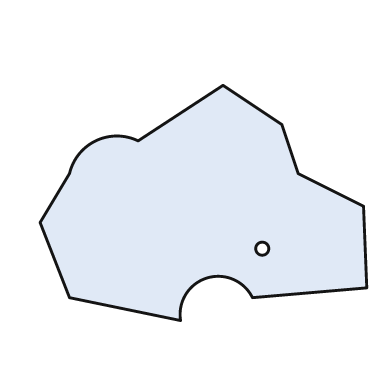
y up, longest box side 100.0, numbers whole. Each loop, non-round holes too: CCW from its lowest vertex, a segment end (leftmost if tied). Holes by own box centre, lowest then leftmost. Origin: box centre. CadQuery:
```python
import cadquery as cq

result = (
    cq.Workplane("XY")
    .moveTo(-7.0, -36.0)
    .threePointArc((1.0, -23.0), (15.0, -29.0))
    .lineTo(50.0, -26.0)
    .lineTo(49.0, -1.0)
    .lineTo(29.0, 9.0)
    .lineTo(24.0, 24.0)
    .lineTo(6.0, 36.0)
    .lineTo(-20.0, 19.0)
    .threePointArc((-33.0, 19.0), (-41.0, 9.0))
    .lineTo(-50.0, -6.0)
    .lineTo(-41.0, -29.0)
    .close()
    .moveTo(18.0, -14.0)
    .circle(2.0)
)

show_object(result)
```